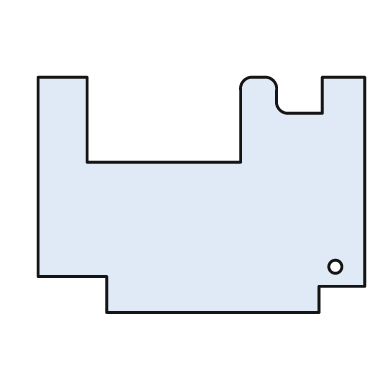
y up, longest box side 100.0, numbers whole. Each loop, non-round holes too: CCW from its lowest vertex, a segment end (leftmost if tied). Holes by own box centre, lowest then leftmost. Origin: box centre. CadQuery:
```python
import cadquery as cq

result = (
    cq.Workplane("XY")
    .moveTo(-29.0, -36.0)
    .lineTo(36.0, -36.0)
    .lineTo(36.0, -28.0)
    .lineTo(50.0, -28.0)
    .lineTo(50.0, 36.0)
    .lineTo(37.0, 36.0)
    .lineTo(37.0, 25.0)
    .lineTo(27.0, 25.0)
    .threePointArc((24.0, 26.0), (23.0, 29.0))
    .lineTo(23.0, 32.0)
    .threePointArc((22.0, 35.0), (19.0, 36.0))
    .lineTo(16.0, 36.0)
    .threePointArc((13.0, 35.0), (12.0, 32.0))
    .lineTo(12.0, 10.0)
    .lineTo(-35.0, 10.0)
    .lineTo(-35.0, 36.0)
    .lineTo(-50.0, 36.0)
    .lineTo(-50.0, -25.0)
    .lineTo(-29.0, -25.0)
    .close()
    .moveTo(41.0, -22.0)
    .circle(2.0)
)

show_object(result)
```